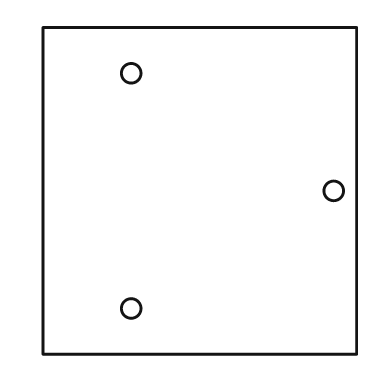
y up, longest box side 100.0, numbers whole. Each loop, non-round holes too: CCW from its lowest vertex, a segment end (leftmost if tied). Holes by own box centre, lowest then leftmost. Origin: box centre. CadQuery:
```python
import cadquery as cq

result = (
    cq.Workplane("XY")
    .moveTo(-48.0, -50.0)
    .lineTo(48.0, -50.0)
    .lineTo(48.0, 50.0)
    .lineTo(-48.0, 50.0)
    .close()
    .moveTo(-21.0, -36.0)
    .circle(3.0)
    .moveTo(41.0, 0.0)
    .circle(3.0)
    .moveTo(-21.0, 36.0)
    .circle(3.0)
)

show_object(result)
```